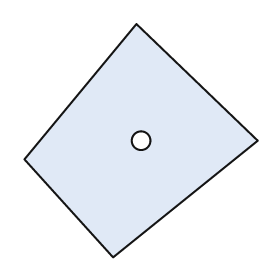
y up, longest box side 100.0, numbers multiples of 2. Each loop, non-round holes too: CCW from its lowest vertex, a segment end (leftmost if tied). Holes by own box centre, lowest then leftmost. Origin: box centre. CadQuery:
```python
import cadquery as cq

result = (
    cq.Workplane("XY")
    .moveTo(-12.0, -50.0)
    .lineTo(50.0, 0.0)
    .lineTo(-2.0, 50.0)
    .lineTo(-50.0, -8.0)
    .close()
    .moveTo(0.0, 0.0)
    .circle(4.0)
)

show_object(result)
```